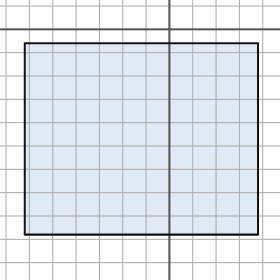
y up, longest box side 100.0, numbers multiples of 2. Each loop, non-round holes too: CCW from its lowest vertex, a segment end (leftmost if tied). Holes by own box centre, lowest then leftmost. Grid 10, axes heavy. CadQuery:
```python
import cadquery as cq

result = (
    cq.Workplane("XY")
    .moveTo(-62.0, -88.0)
    .lineTo(38.0, -88.0)
    .lineTo(38.0, -6.0)
    .lineTo(-62.0, -6.0)
    .close()
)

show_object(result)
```